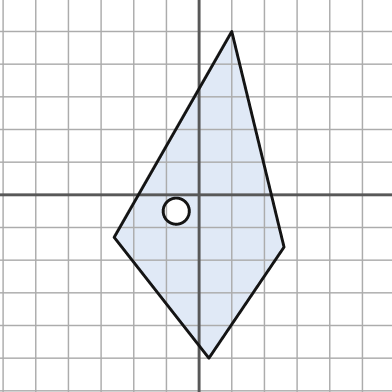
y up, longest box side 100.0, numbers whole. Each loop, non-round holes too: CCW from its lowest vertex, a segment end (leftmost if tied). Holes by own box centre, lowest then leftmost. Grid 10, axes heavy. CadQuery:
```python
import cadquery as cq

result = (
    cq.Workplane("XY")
    .moveTo(3.0, -50.0)
    .lineTo(26.0, -16.0)
    .lineTo(10.0, 50.0)
    .lineTo(-26.0, -13.0)
    .close()
    .moveTo(-7.0, -5.0)
    .circle(4.0)
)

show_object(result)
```